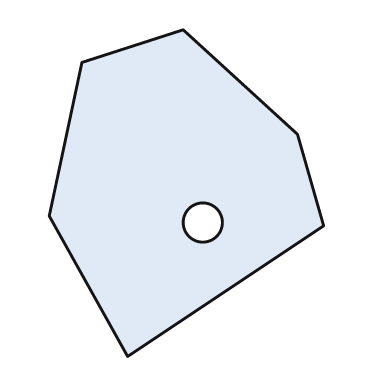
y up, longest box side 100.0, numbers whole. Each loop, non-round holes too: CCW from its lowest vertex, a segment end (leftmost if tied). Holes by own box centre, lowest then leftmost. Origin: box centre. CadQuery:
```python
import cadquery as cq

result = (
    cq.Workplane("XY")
    .moveTo(-18.0, -50.0)
    .lineTo(42.0, -10.0)
    .lineTo(34.0, 18.0)
    .lineTo(-1.0, 50.0)
    .lineTo(-32.0, 40.0)
    .lineTo(-42.0, -7.0)
    .close()
    .moveTo(5.0, -9.0)
    .circle(6.0)
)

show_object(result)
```